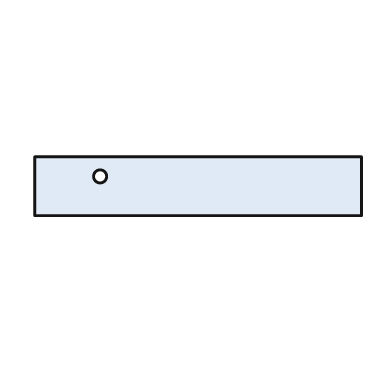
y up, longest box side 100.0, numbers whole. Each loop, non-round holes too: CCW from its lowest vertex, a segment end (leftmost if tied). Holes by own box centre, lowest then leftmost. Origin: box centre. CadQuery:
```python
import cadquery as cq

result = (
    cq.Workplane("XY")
    .moveTo(-50.0, -9.0)
    .lineTo(50.0, -9.0)
    .lineTo(50.0, 9.0)
    .lineTo(-50.0, 9.0)
    .close()
    .moveTo(-30.0, 3.0)
    .circle(2.0)
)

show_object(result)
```